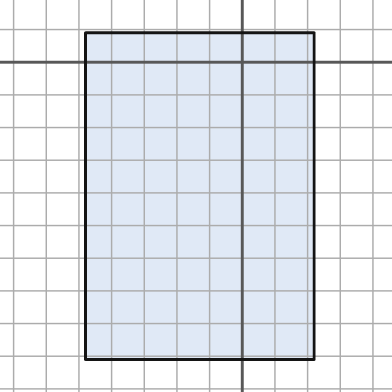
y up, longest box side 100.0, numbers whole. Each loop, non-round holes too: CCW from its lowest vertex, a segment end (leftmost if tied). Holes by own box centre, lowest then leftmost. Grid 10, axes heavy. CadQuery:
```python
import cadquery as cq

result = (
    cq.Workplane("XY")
    .moveTo(-48.0, -91.0)
    .lineTo(22.0, -91.0)
    .lineTo(22.0, 9.0)
    .lineTo(-48.0, 9.0)
    .close()
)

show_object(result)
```